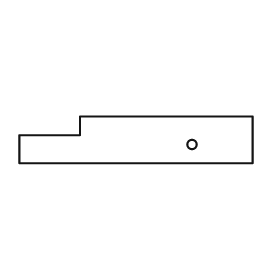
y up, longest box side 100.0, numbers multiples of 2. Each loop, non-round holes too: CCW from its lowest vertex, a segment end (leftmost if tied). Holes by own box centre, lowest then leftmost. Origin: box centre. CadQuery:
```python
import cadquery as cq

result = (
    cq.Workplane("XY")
    .moveTo(-50.0, -10.0)
    .lineTo(50.0, -10.0)
    .lineTo(50.0, 10.0)
    .lineTo(-24.0, 10.0)
    .lineTo(-24.0, 2.0)
    .lineTo(-50.0, 2.0)
    .close()
    .moveTo(24.0, -2.0)
    .circle(2.0)
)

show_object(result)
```